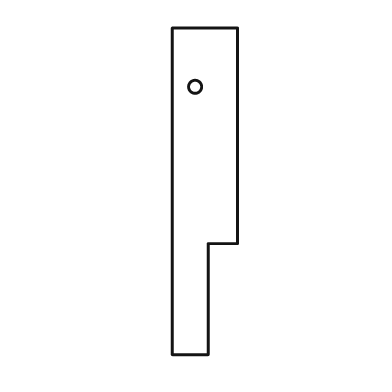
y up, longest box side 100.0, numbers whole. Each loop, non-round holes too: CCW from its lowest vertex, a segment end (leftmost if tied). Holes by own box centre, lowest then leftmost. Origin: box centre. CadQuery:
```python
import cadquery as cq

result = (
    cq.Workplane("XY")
    .moveTo(-10.0, -50.0)
    .lineTo(1.0, -50.0)
    .lineTo(1.0, -16.0)
    .lineTo(10.0, -16.0)
    .lineTo(10.0, 50.0)
    .lineTo(-10.0, 50.0)
    .close()
    .moveTo(-3.0, 32.0)
    .circle(2.0)
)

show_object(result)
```